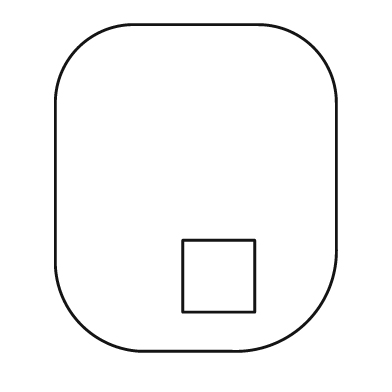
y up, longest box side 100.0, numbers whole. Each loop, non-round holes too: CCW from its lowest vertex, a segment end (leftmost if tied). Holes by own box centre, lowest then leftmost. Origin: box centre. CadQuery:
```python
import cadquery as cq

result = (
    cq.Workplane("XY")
    .moveTo(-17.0, -50.0)
    .lineTo(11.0, -50.0)
    .threePointArc((34.0, -41.0), (43.0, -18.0))
    .lineTo(43.0, 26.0)
    .threePointArc((36.0, 43.0), (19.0, 50.0))
    .lineTo(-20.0, 50.0)
    .threePointArc((-36.0, 43.0), (-43.0, 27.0))
    .lineTo(-43.0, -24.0)
    .threePointArc((-35.0, -42.0), (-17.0, -50.0))
    .close()
    .moveTo(-4.0, -38.0)
    .lineTo(18.0, -38.0)
    .lineTo(18.0, -16.0)
    .lineTo(-4.0, -16.0)
    .close()
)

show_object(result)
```